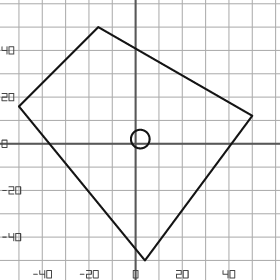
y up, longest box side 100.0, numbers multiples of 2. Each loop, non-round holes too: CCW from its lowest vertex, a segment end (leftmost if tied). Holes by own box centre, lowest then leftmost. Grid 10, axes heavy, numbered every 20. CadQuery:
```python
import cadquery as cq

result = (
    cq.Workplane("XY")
    .moveTo(4.0, -50.0)
    .lineTo(50.0, 12.0)
    .lineTo(-16.0, 50.0)
    .lineTo(-50.0, 16.0)
    .close()
    .moveTo(2.0, 2.0)
    .circle(4.0)
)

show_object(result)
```